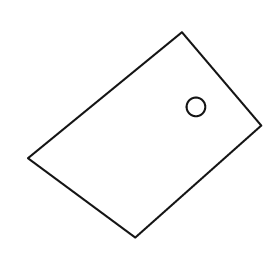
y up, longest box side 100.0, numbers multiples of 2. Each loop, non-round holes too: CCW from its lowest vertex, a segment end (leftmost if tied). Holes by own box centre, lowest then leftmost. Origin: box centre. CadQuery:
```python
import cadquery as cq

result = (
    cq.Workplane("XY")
    .moveTo(-4.0, -44.0)
    .lineTo(50.0, 4.0)
    .lineTo(16.0, 44.0)
    .lineTo(-50.0, -10.0)
    .close()
    .moveTo(22.0, 12.0)
    .circle(4.0)
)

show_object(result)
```